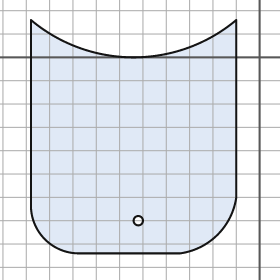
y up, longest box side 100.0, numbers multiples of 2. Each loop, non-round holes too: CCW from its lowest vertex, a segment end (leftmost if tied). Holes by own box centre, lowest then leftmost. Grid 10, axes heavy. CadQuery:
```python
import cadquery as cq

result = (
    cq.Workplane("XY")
    .moveTo(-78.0, -84.0)
    .lineTo(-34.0, -84.0)
    .threePointArc((-18.0, -76.0), (-10.0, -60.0))
    .lineTo(-10.0, 16.0)
    .threePointArc((-54.0, 0.0), (-98.0, 16.0))
    .lineTo(-98.0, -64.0)
    .threePointArc((-92.0, -78.0), (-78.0, -84.0))
    .close()
    .moveTo(-52.0, -70.0)
    .circle(2.0)
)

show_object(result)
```